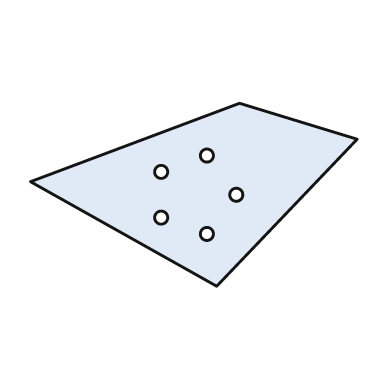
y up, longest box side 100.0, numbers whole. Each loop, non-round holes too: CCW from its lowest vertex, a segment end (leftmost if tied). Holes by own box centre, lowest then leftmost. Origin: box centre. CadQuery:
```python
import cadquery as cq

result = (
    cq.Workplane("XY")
    .moveTo(7.0, -28.0)
    .lineTo(50.0, 17.0)
    .lineTo(14.0, 28.0)
    .lineTo(-50.0, 4.0)
    .close()
    .moveTo(4.0, -12.0)
    .circle(2.0)
    .moveTo(-10.0, -7.0)
    .circle(2.0)
    .moveTo(13.0, 0.0)
    .circle(2.0)
    .moveTo(-10.0, 7.0)
    .circle(2.0)
    .moveTo(4.0, 12.0)
    .circle(2.0)
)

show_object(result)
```